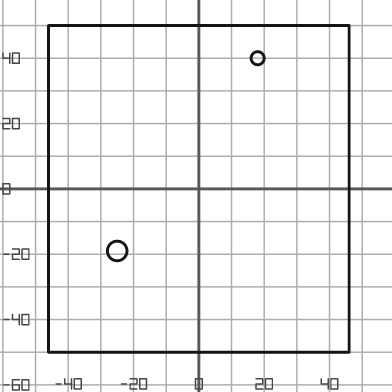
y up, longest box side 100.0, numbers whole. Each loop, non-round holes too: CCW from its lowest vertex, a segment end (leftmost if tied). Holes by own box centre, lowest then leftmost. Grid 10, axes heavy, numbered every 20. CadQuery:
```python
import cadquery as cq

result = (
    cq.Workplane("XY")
    .moveTo(-46.0, -50.0)
    .lineTo(46.0, -50.0)
    .lineTo(46.0, 50.0)
    .lineTo(-46.0, 50.0)
    .close()
    .moveTo(-25.0, -19.0)
    .circle(3.0)
    .moveTo(18.0, 40.0)
    .circle(2.0)
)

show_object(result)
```